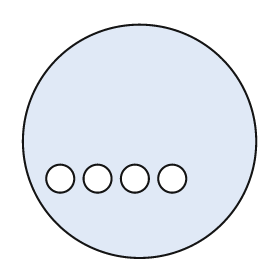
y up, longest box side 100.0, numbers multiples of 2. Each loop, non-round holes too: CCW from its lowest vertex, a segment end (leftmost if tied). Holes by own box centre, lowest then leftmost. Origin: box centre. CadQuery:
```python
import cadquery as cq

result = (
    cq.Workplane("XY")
    .moveTo(0.0, 0.0)
    .circle(50.0)
    .moveTo(-34.0, -16.0)
    .circle(6.0)
    .moveTo(-18.0, -16.0)
    .circle(6.0)
    .moveTo(-2.0, -16.0)
    .circle(6.0)
    .moveTo(14.0, -16.0)
    .circle(6.0)
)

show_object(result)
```